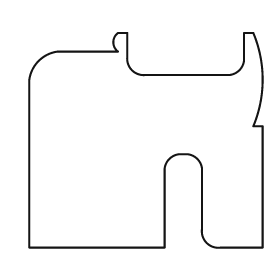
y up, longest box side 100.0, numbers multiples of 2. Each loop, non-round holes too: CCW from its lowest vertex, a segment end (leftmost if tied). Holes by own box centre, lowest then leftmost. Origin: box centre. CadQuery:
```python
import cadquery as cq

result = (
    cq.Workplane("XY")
    .moveTo(-50.0, -46.0)
    .lineTo(8.0, -46.0)
    .lineTo(8.0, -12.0)
    .threePointArc((10.0, -8.0), (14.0, -6.0))
    .lineTo(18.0, -6.0)
    .threePointArc((22.0, -8.0), (24.0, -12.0))
    .lineTo(24.0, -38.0)
    .threePointArc((26.0, -44.0), (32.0, -46.0))
    .lineTo(50.0, -46.0)
    .lineTo(50.0, 6.0)
    .lineTo(46.0, 6.0)
    .threePointArc((50.0, 26.0), (46.0, 46.0))
    .lineTo(42.0, 46.0)
    .lineTo(42.0, 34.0)
    .threePointArc((40.0, 30.0), (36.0, 28.0))
    .lineTo(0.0, 28.0)
    .threePointArc((-6.0, 30.0), (-8.0, 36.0))
    .lineTo(-8.0, 46.0)
    .lineTo(-12.0, 46.0)
    .threePointArc((-14.0, 42.0), (-12.0, 38.0))
    .lineTo(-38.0, 38.0)
    .threePointArc((-46.0, 34.0), (-50.0, 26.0))
    .close()
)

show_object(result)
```